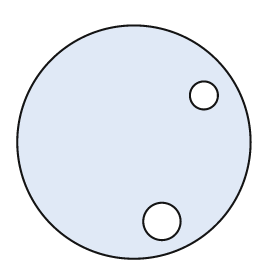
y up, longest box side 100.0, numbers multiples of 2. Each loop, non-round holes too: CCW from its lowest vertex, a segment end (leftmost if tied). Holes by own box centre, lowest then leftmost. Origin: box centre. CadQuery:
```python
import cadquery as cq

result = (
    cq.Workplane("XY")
    .moveTo(0.0, 0.0)
    .circle(50.0)
    .moveTo(12.0, -34.0)
    .circle(8.0)
    .moveTo(30.0, 20.0)
    .circle(6.0)
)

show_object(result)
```